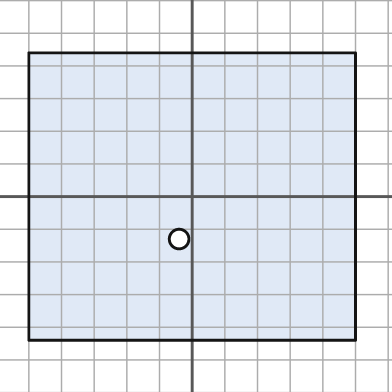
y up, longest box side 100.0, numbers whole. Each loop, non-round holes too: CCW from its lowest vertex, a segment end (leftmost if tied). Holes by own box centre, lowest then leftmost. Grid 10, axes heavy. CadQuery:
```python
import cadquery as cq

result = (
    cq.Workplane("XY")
    .moveTo(-50.0, -44.0)
    .lineTo(50.0, -44.0)
    .lineTo(50.0, 44.0)
    .lineTo(-50.0, 44.0)
    .close()
    .moveTo(-4.0, -13.0)
    .circle(3.0)
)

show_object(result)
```